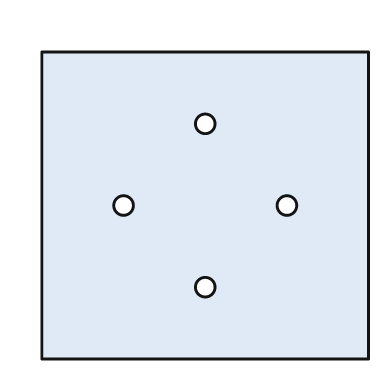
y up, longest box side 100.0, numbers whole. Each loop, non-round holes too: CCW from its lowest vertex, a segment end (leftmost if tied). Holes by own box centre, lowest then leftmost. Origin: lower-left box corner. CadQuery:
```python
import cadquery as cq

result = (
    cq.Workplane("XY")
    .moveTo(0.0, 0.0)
    .lineTo(100.0, 0.0)
    .lineTo(100.0, 94.0)
    .lineTo(0.0, 94.0)
    .close()
    .moveTo(50.0, 22.0)
    .circle(3.0)
    .moveTo(25.0, 47.0)
    .circle(3.0)
    .moveTo(75.0, 47.0)
    .circle(3.0)
    .moveTo(50.0, 72.0)
    .circle(3.0)
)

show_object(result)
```